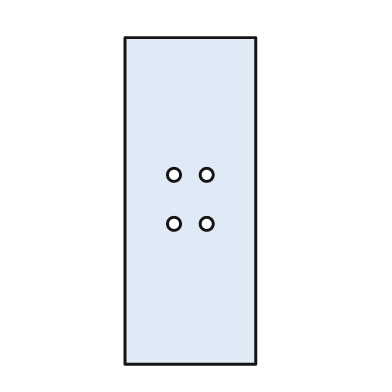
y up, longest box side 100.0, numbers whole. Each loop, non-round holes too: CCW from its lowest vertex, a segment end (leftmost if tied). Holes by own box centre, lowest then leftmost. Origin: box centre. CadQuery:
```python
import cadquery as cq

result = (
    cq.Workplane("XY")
    .moveTo(-20.0, -50.0)
    .lineTo(20.0, -50.0)
    .lineTo(20.0, 50.0)
    .lineTo(-20.0, 50.0)
    .close()
    .moveTo(-5.0, -7.0)
    .circle(2.0)
    .moveTo(5.0, -7.0)
    .circle(2.0)
    .moveTo(-5.0, 8.0)
    .circle(2.0)
    .moveTo(5.0, 8.0)
    .circle(2.0)
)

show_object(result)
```